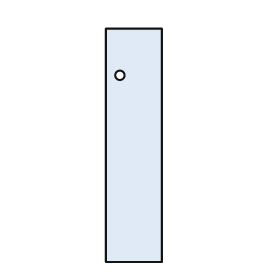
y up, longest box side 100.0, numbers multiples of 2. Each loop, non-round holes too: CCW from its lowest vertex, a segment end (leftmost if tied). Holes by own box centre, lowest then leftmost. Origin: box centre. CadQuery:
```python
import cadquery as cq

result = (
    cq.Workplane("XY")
    .moveTo(-12.0, -50.0)
    .lineTo(12.0, -50.0)
    .lineTo(12.0, 50.0)
    .lineTo(-12.0, 50.0)
    .close()
    .moveTo(-6.0, 30.0)
    .circle(2.0)
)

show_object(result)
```